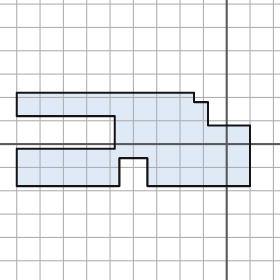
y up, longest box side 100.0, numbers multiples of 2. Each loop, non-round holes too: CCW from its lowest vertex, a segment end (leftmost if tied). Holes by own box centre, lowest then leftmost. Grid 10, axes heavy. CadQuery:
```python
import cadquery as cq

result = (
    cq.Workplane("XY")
    .moveTo(-90.0, -18.0)
    .lineTo(-46.0, -18.0)
    .lineTo(-46.0, -6.0)
    .lineTo(-34.0, -6.0)
    .lineTo(-34.0, -18.0)
    .lineTo(10.0, -18.0)
    .lineTo(10.0, 8.0)
    .lineTo(-8.0, 8.0)
    .lineTo(-8.0, 18.0)
    .lineTo(-14.0, 18.0)
    .lineTo(-14.0, 22.0)
    .lineTo(-90.0, 22.0)
    .lineTo(-90.0, 12.0)
    .lineTo(-48.0, 12.0)
    .lineTo(-48.0, -2.0)
    .lineTo(-90.0, -2.0)
    .close()
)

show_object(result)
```